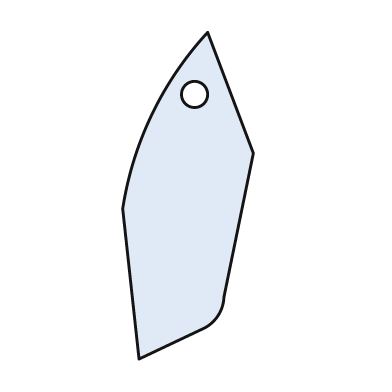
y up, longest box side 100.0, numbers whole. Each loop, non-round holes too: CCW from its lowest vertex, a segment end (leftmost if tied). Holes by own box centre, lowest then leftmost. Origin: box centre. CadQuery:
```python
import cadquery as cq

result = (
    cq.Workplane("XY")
    .moveTo(-15.0, -50.0)
    .lineTo(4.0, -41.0)
    .threePointArc((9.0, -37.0), (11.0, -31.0))
    .lineTo(20.0, 13.0)
    .lineTo(6.0, 50.0)
    .threePointArc((-11.0, 25.0), (-20.0, -4.0))
    .close()
    .moveTo(2.0, 31.0)
    .circle(4.0)
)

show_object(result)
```